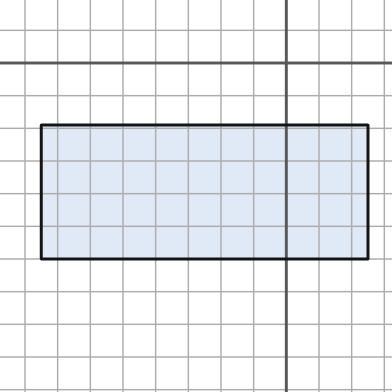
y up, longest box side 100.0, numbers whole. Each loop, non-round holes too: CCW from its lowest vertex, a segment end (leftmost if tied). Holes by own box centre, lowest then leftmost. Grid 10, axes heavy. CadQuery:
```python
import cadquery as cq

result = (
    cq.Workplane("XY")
    .moveTo(-75.0, -60.0)
    .lineTo(25.0, -60.0)
    .lineTo(25.0, -19.0)
    .lineTo(-75.0, -19.0)
    .close()
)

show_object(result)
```